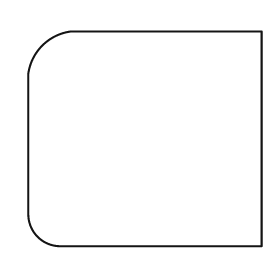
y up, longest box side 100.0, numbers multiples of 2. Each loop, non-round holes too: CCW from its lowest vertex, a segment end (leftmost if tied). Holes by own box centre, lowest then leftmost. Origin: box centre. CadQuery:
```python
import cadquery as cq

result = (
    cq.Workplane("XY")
    .moveTo(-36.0, -46.0)
    .lineTo(50.0, -46.0)
    .lineTo(50.0, 46.0)
    .lineTo(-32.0, 46.0)
    .threePointArc((-44.0, 40.0), (-50.0, 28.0))
    .lineTo(-50.0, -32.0)
    .threePointArc((-46.0, -42.0), (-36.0, -46.0))
    .close()
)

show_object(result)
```